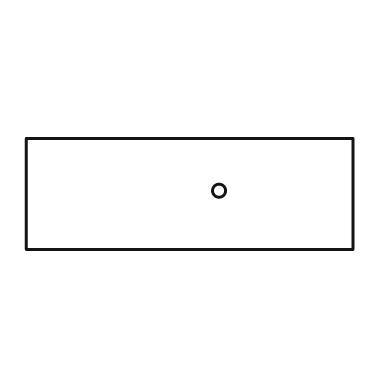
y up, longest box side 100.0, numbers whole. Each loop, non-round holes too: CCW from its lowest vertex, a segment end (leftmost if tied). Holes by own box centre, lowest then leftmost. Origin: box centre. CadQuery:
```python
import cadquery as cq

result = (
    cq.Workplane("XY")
    .moveTo(-50.0, -17.0)
    .lineTo(50.0, -17.0)
    .lineTo(50.0, 17.0)
    .lineTo(-50.0, 17.0)
    .close()
    .moveTo(9.0, 1.0)
    .circle(2.0)
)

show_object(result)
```